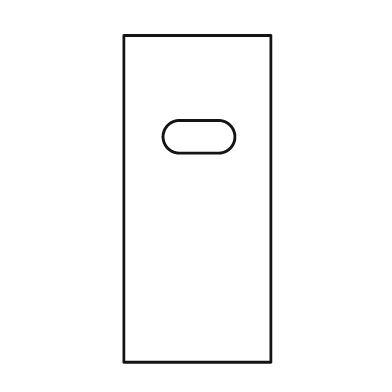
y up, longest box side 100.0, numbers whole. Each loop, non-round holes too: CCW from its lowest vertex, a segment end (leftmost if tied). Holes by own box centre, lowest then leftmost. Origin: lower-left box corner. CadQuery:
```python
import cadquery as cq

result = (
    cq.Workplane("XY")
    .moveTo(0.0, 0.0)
    .lineTo(45.0, 0.0)
    .lineTo(45.0, 100.0)
    .lineTo(0.0, 100.0)
    .close()
    .moveTo(17.0, 64.0)
    .lineTo(29.0, 64.0)
    .threePointArc((34.0, 69.0), (29.0, 74.0))
    .lineTo(17.0, 74.0)
    .threePointArc((12.0, 69.0), (17.0, 64.0))
    .close()
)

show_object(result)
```